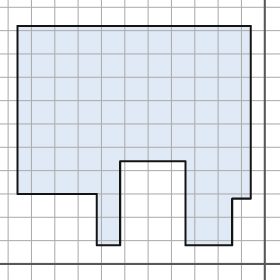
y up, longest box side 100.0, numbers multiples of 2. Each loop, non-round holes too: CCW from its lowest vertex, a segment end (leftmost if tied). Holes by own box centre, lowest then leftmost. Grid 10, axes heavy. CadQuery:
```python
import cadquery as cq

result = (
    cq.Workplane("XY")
    .moveTo(-72.0, 8.0)
    .lineTo(-62.0, 8.0)
    .lineTo(-62.0, 44.0)
    .lineTo(-34.0, 44.0)
    .lineTo(-34.0, 8.0)
    .lineTo(-14.0, 8.0)
    .lineTo(-14.0, 28.0)
    .lineTo(-6.0, 28.0)
    .lineTo(-6.0, 102.0)
    .lineTo(-106.0, 102.0)
    .lineTo(-106.0, 30.0)
    .lineTo(-72.0, 30.0)
    .close()
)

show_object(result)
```